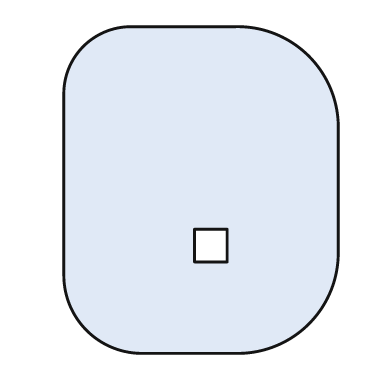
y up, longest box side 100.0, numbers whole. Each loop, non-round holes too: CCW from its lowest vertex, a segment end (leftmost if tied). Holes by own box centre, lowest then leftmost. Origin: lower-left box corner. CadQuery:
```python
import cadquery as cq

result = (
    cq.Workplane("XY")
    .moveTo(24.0, 0.0)
    .lineTo(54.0, 0.0)
    .threePointArc((75.0, 9.0), (84.0, 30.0))
    .lineTo(84.0, 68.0)
    .threePointArc((75.0, 91.0), (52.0, 100.0))
    .lineTo(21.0, 100.0)
    .threePointArc((6.0, 94.0), (0.0, 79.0))
    .lineTo(0.0, 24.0)
    .threePointArc((7.0, 7.0), (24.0, 0.0))
    .close()
    .moveTo(40.0, 28.0)
    .lineTo(50.0, 28.0)
    .lineTo(50.0, 38.0)
    .lineTo(40.0, 38.0)
    .close()
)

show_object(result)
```